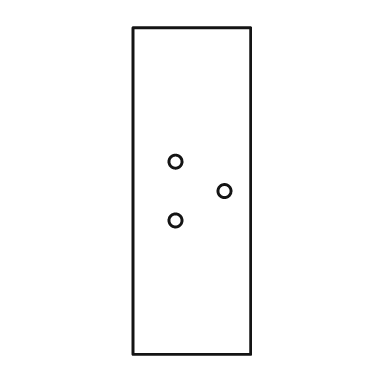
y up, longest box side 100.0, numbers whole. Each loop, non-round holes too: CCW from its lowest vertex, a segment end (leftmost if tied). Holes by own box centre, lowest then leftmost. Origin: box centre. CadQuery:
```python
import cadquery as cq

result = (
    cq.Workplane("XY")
    .moveTo(-18.0, -50.0)
    .lineTo(18.0, -50.0)
    .lineTo(18.0, 50.0)
    .lineTo(-18.0, 50.0)
    .close()
    .moveTo(-5.0, -9.0)
    .circle(2.0)
    .moveTo(10.0, 0.0)
    .circle(2.0)
    .moveTo(-5.0, 9.0)
    .circle(2.0)
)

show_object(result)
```